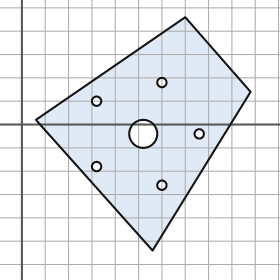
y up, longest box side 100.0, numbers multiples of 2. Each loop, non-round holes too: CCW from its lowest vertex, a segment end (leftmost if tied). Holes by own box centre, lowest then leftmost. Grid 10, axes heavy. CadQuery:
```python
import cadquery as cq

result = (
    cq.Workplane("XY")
    .moveTo(56.0, -54.0)
    .lineTo(98.0, 14.0)
    .lineTo(70.0, 46.0)
    .lineTo(6.0, 2.0)
    .close()
    .moveTo(60.0, -26.0)
    .circle(2.0)
    .moveTo(32.0, -18.0)
    .circle(2.0)
    .moveTo(52.0, -4.0)
    .circle(6.0)
    .moveTo(76.0, -4.0)
    .circle(2.0)
    .moveTo(32.0, 10.0)
    .circle(2.0)
    .moveTo(60.0, 18.0)
    .circle(2.0)
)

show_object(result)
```